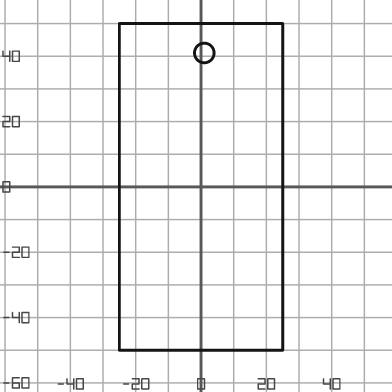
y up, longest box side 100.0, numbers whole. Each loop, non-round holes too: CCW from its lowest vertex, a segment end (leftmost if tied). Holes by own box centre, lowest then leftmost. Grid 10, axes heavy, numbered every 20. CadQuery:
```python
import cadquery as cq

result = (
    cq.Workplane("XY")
    .moveTo(-25.0, -50.0)
    .lineTo(25.0, -50.0)
    .lineTo(25.0, 50.0)
    .lineTo(-25.0, 50.0)
    .close()
    .moveTo(1.0, 41.0)
    .circle(3.0)
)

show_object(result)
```